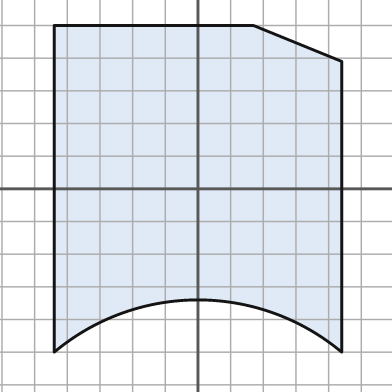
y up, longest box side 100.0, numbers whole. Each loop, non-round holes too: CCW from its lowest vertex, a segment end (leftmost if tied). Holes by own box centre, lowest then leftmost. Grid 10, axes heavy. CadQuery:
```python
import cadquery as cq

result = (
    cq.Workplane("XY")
    .moveTo(-44.0, -50.0)
    .threePointArc((0.0, -34.0), (44.0, -50.0))
    .lineTo(44.0, 39.0)
    .lineTo(17.0, 50.0)
    .lineTo(-44.0, 50.0)
    .close()
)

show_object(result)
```